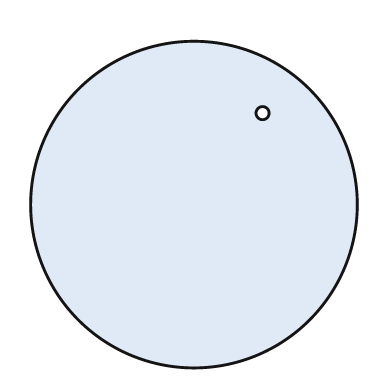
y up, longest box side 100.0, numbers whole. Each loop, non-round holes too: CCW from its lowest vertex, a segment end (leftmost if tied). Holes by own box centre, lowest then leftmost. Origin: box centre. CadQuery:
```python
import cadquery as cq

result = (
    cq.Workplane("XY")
    .moveTo(0.0, 0.0)
    .circle(50.0)
    .moveTo(21.0, 28.0)
    .circle(2.0)
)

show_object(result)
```